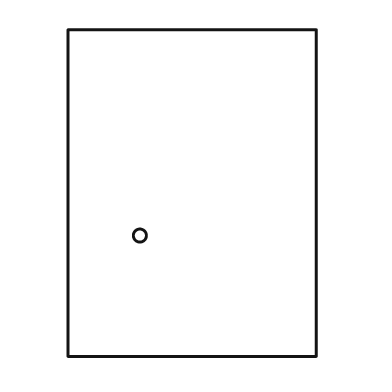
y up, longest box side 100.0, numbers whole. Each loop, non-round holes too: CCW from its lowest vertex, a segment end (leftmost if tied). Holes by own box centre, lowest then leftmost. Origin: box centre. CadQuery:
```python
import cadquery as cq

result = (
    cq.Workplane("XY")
    .moveTo(-38.0, -50.0)
    .lineTo(38.0, -50.0)
    .lineTo(38.0, 50.0)
    .lineTo(-38.0, 50.0)
    .close()
    .moveTo(-16.0, -13.0)
    .circle(2.0)
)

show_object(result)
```